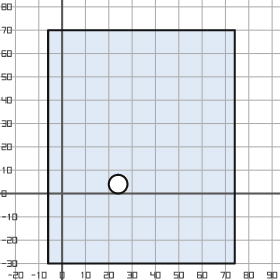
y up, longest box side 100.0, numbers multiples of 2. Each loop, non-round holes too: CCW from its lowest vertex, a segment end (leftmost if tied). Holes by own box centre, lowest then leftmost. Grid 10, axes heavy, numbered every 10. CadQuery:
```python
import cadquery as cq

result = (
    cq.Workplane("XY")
    .moveTo(-6.0, -30.0)
    .lineTo(74.0, -30.0)
    .lineTo(74.0, 70.0)
    .lineTo(-6.0, 70.0)
    .close()
    .moveTo(24.0, 4.0)
    .circle(4.0)
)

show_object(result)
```